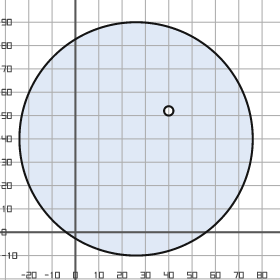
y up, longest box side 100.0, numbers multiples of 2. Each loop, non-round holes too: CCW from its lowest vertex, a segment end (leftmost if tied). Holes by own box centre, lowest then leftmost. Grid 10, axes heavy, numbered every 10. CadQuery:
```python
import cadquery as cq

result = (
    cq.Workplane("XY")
    .moveTo(26.0, 40.0)
    .circle(50.0)
    .moveTo(40.0, 52.0)
    .circle(2.0)
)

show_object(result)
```